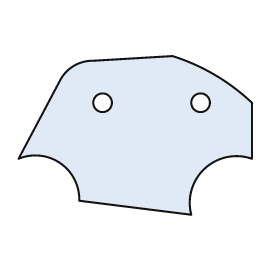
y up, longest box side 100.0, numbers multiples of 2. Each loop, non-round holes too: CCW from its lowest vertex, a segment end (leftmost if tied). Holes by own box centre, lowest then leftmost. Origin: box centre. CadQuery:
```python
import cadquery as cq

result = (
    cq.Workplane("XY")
    .moveTo(24.0, -34.0)
    .threePointArc((30.0, -14.0), (50.0, -10.0))
    .lineTo(50.0, 14.0)
    .threePointArc((34.0, 26.0), (16.0, 34.0))
    .lineTo(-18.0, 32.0)
    .threePointArc((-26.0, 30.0), (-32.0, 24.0))
    .lineTo(-50.0, -10.0)
    .threePointArc((-32.0, -12.0), (-24.0, -28.0))
    .close()
    .moveTo(-14.0, 14.0)
    .circle(4.0)
    .moveTo(28.0, 14.0)
    .circle(4.0)
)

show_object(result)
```